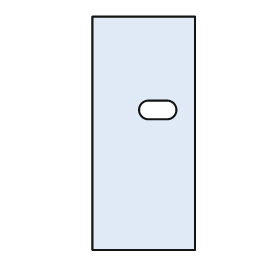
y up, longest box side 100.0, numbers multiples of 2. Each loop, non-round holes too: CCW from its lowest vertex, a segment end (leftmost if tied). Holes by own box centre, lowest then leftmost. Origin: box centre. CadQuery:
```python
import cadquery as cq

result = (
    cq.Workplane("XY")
    .moveTo(-22.0, -50.0)
    .lineTo(22.0, -50.0)
    .lineTo(22.0, 50.0)
    .lineTo(-22.0, 50.0)
    .close()
    .moveTo(2.0, 6.0)
    .lineTo(10.0, 6.0)
    .threePointArc((14.0, 10.0), (10.0, 14.0))
    .lineTo(2.0, 14.0)
    .threePointArc((-2.0, 10.0), (2.0, 6.0))
    .close()
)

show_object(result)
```